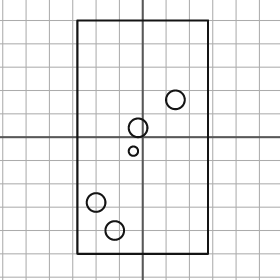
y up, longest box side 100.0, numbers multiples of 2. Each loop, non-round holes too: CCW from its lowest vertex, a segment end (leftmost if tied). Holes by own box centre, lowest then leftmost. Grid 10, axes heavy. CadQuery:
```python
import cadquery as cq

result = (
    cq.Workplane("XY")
    .moveTo(-28.0, -50.0)
    .lineTo(28.0, -50.0)
    .lineTo(28.0, 50.0)
    .lineTo(-28.0, 50.0)
    .close()
    .moveTo(-12.0, -40.0)
    .circle(4.0)
    .moveTo(-20.0, -28.0)
    .circle(4.0)
    .moveTo(-4.0, -6.0)
    .circle(2.0)
    .moveTo(-2.0, 4.0)
    .circle(4.0)
    .moveTo(14.0, 16.0)
    .circle(4.0)
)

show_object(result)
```